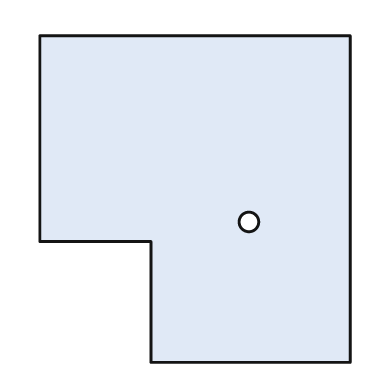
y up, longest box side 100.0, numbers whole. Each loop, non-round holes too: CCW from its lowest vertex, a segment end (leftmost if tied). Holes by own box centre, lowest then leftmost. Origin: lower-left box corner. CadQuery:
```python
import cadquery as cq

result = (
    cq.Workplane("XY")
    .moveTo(34.0, 0.0)
    .lineTo(95.0, 0.0)
    .lineTo(95.0, 100.0)
    .lineTo(0.0, 100.0)
    .lineTo(0.0, 37.0)
    .lineTo(34.0, 37.0)
    .close()
    .moveTo(64.0, 43.0)
    .circle(3.0)
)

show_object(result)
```